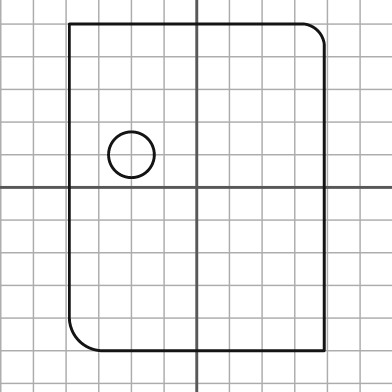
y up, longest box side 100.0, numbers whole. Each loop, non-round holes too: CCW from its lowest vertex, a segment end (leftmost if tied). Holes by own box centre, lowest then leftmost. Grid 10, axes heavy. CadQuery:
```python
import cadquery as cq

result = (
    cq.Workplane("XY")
    .moveTo(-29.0, -50.0)
    .lineTo(39.0, -50.0)
    .lineTo(39.0, 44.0)
    .threePointArc((37.0, 48.0), (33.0, 50.0))
    .lineTo(-39.0, 50.0)
    .lineTo(-39.0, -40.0)
    .threePointArc((-36.0, -47.0), (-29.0, -50.0))
    .close()
    .moveTo(-20.0, 10.0)
    .circle(7.0)
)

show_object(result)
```